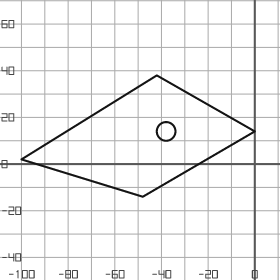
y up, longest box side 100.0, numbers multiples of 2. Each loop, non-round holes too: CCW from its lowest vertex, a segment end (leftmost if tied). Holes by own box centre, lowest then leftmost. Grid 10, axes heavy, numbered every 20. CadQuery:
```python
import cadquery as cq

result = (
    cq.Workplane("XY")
    .moveTo(-48.0, -14.0)
    .lineTo(0.0, 14.0)
    .lineTo(-42.0, 38.0)
    .lineTo(-100.0, 2.0)
    .close()
    .moveTo(-38.0, 14.0)
    .circle(4.0)
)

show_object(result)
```